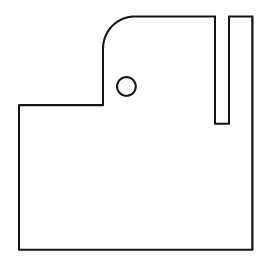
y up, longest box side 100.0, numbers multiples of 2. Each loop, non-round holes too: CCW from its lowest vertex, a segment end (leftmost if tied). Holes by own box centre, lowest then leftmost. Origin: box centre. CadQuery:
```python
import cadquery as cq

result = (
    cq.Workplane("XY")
    .moveTo(-50.0, -50.0)
    .lineTo(50.0, -50.0)
    .lineTo(50.0, 50.0)
    .lineTo(40.0, 50.0)
    .lineTo(40.0, 4.0)
    .lineTo(34.0, 4.0)
    .lineTo(34.0, 50.0)
    .lineTo(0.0, 50.0)
    .threePointArc((-10.0, 46.0), (-14.0, 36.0))
    .lineTo(-14.0, 12.0)
    .lineTo(-50.0, 12.0)
    .close()
    .moveTo(-4.0, 20.0)
    .circle(4.0)
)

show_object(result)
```